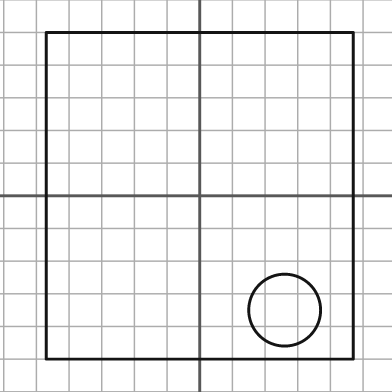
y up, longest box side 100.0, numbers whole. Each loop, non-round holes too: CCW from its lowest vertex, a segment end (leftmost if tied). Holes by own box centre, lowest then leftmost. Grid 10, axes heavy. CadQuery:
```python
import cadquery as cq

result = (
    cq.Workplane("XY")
    .moveTo(-47.0, -50.0)
    .lineTo(47.0, -50.0)
    .lineTo(47.0, 50.0)
    .lineTo(-47.0, 50.0)
    .close()
    .moveTo(26.0, -35.0)
    .circle(11.0)
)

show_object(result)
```